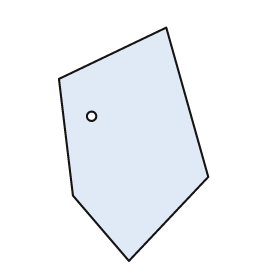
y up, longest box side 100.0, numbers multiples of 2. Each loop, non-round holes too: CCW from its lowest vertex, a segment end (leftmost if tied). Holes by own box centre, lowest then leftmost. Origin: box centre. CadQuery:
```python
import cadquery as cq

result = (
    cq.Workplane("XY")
    .moveTo(-2.0, -50.0)
    .lineTo(32.0, -14.0)
    .lineTo(14.0, 50.0)
    .lineTo(-32.0, 28.0)
    .lineTo(-26.0, -22.0)
    .close()
    .moveTo(-18.0, 12.0)
    .circle(2.0)
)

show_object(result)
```